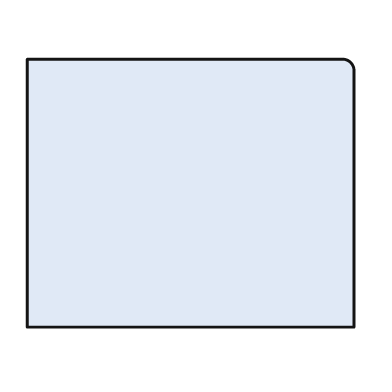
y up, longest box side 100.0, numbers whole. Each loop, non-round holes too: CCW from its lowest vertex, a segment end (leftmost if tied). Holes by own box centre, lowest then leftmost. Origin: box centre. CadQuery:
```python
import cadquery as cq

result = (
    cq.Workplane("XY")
    .moveTo(-50.0, -41.0)
    .lineTo(50.0, -41.0)
    .lineTo(50.0, 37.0)
    .threePointArc((49.0, 40.0), (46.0, 41.0))
    .lineTo(-50.0, 41.0)
    .close()
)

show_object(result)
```